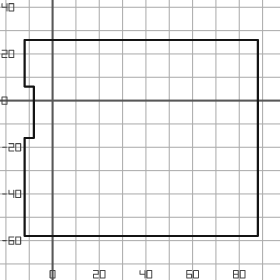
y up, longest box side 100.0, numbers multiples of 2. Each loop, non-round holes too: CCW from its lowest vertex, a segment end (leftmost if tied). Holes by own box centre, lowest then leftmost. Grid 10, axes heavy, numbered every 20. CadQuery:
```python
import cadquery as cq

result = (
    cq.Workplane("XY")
    .moveTo(-12.0, -58.0)
    .lineTo(88.0, -58.0)
    .lineTo(88.0, 26.0)
    .lineTo(-12.0, 26.0)
    .lineTo(-12.0, 6.0)
    .lineTo(-8.0, 6.0)
    .lineTo(-8.0, -16.0)
    .lineTo(-12.0, -16.0)
    .close()
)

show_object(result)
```